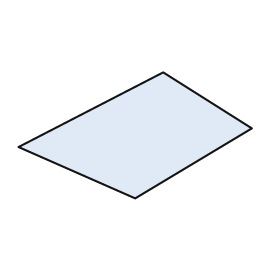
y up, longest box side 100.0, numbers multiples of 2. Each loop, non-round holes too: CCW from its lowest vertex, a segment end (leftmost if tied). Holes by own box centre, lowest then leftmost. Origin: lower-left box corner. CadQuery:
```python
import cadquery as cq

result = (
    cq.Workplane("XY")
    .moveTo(50.0, 0.0)
    .lineTo(100.0, 30.0)
    .lineTo(62.0, 54.0)
    .lineTo(0.0, 22.0)
    .close()
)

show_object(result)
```